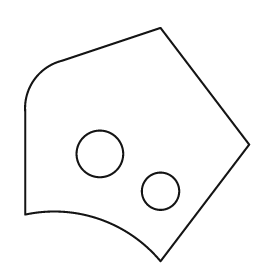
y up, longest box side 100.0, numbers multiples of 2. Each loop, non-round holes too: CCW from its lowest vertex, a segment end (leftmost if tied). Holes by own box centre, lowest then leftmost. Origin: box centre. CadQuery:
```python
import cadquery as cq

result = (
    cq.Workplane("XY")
    .moveTo(10.0, -50.0)
    .lineTo(48.0, 0.0)
    .lineTo(10.0, 50.0)
    .lineTo(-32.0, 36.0)
    .threePointArc((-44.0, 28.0), (-48.0, 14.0))
    .lineTo(-48.0, -30.0)
    .threePointArc((-16.0, -32.0), (10.0, -50.0))
    .close()
    .moveTo(10.0, -20.0)
    .circle(8.0)
    .moveTo(-16.0, -4.0)
    .circle(10.0)
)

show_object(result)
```